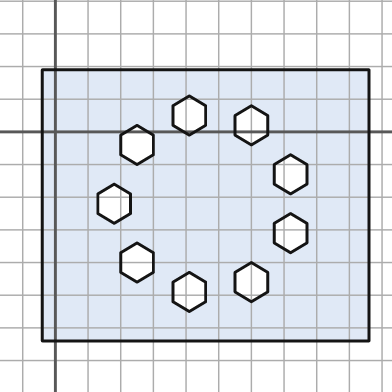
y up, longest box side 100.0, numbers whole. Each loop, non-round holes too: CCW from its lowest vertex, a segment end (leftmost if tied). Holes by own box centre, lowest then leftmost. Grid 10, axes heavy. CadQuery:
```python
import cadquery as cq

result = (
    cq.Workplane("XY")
    .moveTo(-4.0, -64.0)
    .lineTo(96.0, -64.0)
    .lineTo(96.0, 19.0)
    .lineTo(-4.0, 19.0)
    .close()
    .moveTo(41.0, -55.0)
    .lineTo(46.0, -52.0)
    .lineTo(46.0, -46.0)
    .lineTo(41.0, -43.0)
    .lineTo(36.0, -46.0)
    .lineTo(36.0, -52.0)
    .close()
    .moveTo(60.0, -52.0)
    .lineTo(65.0, -49.0)
    .lineTo(65.0, -43.0)
    .lineTo(60.0, -40.0)
    .lineTo(55.0, -43.0)
    .lineTo(55.0, -49.0)
    .close()
    .moveTo(25.0, -46.0)
    .lineTo(30.0, -43.0)
    .lineTo(30.0, -37.0)
    .lineTo(25.0, -34.0)
    .lineTo(20.0, -37.0)
    .lineTo(20.0, -43.0)
    .close()
    .moveTo(72.0, -37.0)
    .lineTo(77.0, -34.0)
    .lineTo(77.0, -28.0)
    .lineTo(72.0, -25.0)
    .lineTo(67.0, -28.0)
    .lineTo(67.0, -34.0)
    .close()
    .moveTo(18.0, -28.0)
    .lineTo(23.0, -25.0)
    .lineTo(23.0, -19.0)
    .lineTo(18.0, -16.0)
    .lineTo(13.0, -19.0)
    .lineTo(13.0, -25.0)
    .close()
    .moveTo(72.0, -19.0)
    .lineTo(77.0, -16.0)
    .lineTo(77.0, -10.0)
    .lineTo(72.0, -7.0)
    .lineTo(67.0, -10.0)
    .lineTo(67.0, -16.0)
    .close()
    .moveTo(25.0, -10.0)
    .lineTo(30.0, -7.0)
    .lineTo(30.0, -1.0)
    .lineTo(25.0, 2.0)
    .lineTo(20.0, -1.0)
    .lineTo(20.0, -7.0)
    .close()
    .moveTo(60.0, -4.0)
    .lineTo(65.0, -1.0)
    .lineTo(65.0, 5.0)
    .lineTo(60.0, 8.0)
    .lineTo(55.0, 5.0)
    .lineTo(55.0, -1.0)
    .close()
    .moveTo(41.0, -1.0)
    .lineTo(46.0, 2.0)
    .lineTo(46.0, 8.0)
    .lineTo(41.0, 11.0)
    .lineTo(36.0, 8.0)
    .lineTo(36.0, 2.0)
    .close()
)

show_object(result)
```